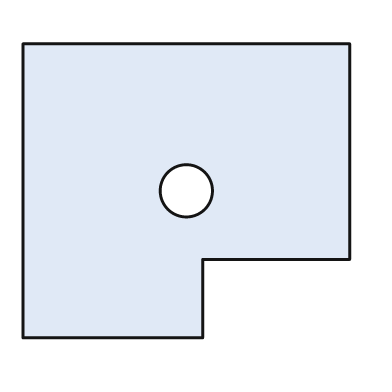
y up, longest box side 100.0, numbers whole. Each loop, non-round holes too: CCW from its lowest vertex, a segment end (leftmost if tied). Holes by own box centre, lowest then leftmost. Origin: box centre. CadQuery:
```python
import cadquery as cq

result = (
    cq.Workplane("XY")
    .moveTo(-50.0, -45.0)
    .lineTo(5.0, -45.0)
    .lineTo(5.0, -21.0)
    .lineTo(50.0, -21.0)
    .lineTo(50.0, 45.0)
    .lineTo(-50.0, 45.0)
    .close()
    .moveTo(0.0, 0.0)
    .circle(8.0)
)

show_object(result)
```